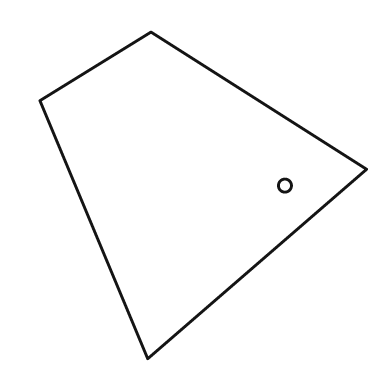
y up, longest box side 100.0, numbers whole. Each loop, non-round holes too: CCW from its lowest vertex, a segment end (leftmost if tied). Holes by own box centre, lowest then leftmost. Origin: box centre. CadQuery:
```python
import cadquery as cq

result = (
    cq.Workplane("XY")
    .moveTo(-17.0, -50.0)
    .lineTo(50.0, 8.0)
    .lineTo(-16.0, 50.0)
    .lineTo(-50.0, 29.0)
    .close()
    .moveTo(25.0, 3.0)
    .circle(2.0)
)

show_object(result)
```